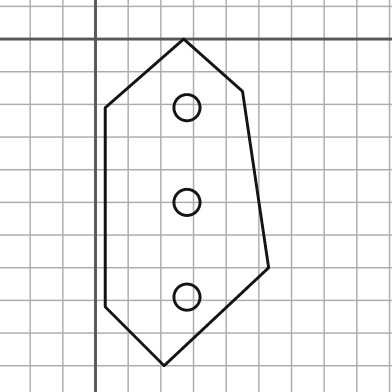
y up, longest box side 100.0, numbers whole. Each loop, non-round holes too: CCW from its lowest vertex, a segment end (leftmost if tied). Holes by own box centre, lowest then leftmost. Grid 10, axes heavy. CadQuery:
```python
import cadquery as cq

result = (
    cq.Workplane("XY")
    .moveTo(21.0, -100.0)
    .lineTo(53.0, -70.0)
    .lineTo(45.0, -16.0)
    .lineTo(27.0, 0.0)
    .lineTo(3.0, -21.0)
    .lineTo(3.0, -82.0)
    .close()
    .moveTo(28.0, -79.0)
    .circle(4.0)
    .moveTo(28.0, -50.0)
    .circle(4.0)
    .moveTo(28.0, -21.0)
    .circle(4.0)
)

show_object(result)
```